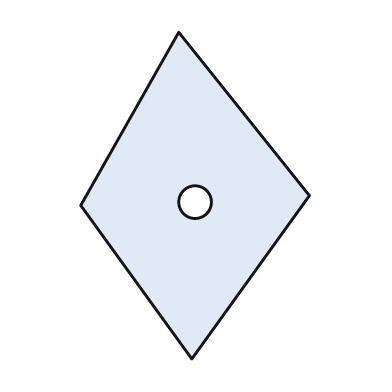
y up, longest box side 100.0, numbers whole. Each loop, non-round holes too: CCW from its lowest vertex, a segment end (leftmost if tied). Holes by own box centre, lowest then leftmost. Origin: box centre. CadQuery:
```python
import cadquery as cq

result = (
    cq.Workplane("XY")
    .moveTo(-1.0, -50.0)
    .lineTo(35.0, 0.0)
    .lineTo(-5.0, 50.0)
    .lineTo(-35.0, -3.0)
    .close()
    .moveTo(0.0, -2.0)
    .circle(5.0)
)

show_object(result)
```